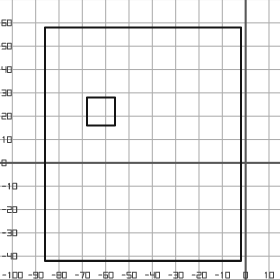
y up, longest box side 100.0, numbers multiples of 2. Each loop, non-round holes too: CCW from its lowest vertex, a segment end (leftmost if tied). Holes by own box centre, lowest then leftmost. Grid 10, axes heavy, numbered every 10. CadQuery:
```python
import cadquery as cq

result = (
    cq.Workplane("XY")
    .moveTo(-86.0, -42.0)
    .lineTo(-2.0, -42.0)
    .lineTo(-2.0, 58.0)
    .lineTo(-86.0, 58.0)
    .close()
    .moveTo(-68.0, 16.0)
    .lineTo(-56.0, 16.0)
    .lineTo(-56.0, 28.0)
    .lineTo(-68.0, 28.0)
    .close()
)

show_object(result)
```